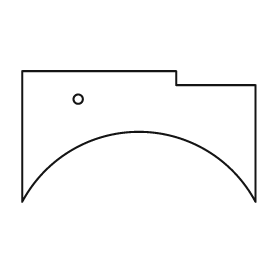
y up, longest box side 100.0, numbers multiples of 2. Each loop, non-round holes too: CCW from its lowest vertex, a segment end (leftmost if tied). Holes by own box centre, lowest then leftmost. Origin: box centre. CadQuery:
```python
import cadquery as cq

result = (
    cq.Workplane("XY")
    .moveTo(-50.0, -28.0)
    .threePointArc((0.0, 2.0), (50.0, -28.0))
    .lineTo(50.0, 22.0)
    .lineTo(16.0, 22.0)
    .lineTo(16.0, 28.0)
    .lineTo(-50.0, 28.0)
    .close()
    .moveTo(-26.0, 16.0)
    .circle(2.0)
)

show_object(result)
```